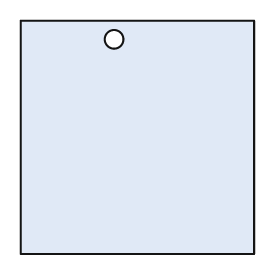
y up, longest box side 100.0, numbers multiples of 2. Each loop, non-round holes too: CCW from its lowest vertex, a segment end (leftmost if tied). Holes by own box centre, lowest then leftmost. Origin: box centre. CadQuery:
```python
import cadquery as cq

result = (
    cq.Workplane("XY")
    .moveTo(-50.0, -50.0)
    .lineTo(50.0, -50.0)
    .lineTo(50.0, 50.0)
    .lineTo(-50.0, 50.0)
    .close()
    .moveTo(-10.0, 42.0)
    .circle(4.0)
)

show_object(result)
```